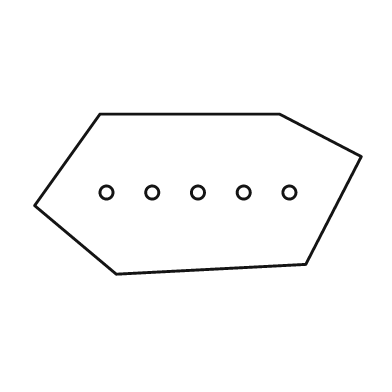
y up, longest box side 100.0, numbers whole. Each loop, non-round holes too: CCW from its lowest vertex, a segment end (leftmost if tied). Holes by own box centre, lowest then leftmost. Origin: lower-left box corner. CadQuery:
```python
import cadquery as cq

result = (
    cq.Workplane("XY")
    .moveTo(25.0, 0.0)
    .lineTo(83.0, 3.0)
    .lineTo(100.0, 36.0)
    .lineTo(75.0, 49.0)
    .lineTo(20.0, 49.0)
    .lineTo(0.0, 21.0)
    .close()
    .moveTo(22.0, 25.0)
    .circle(2.0)
    .moveTo(36.0, 25.0)
    .circle(2.0)
    .moveTo(50.0, 25.0)
    .circle(2.0)
    .moveTo(64.0, 25.0)
    .circle(2.0)
    .moveTo(78.0, 25.0)
    .circle(2.0)
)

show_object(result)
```